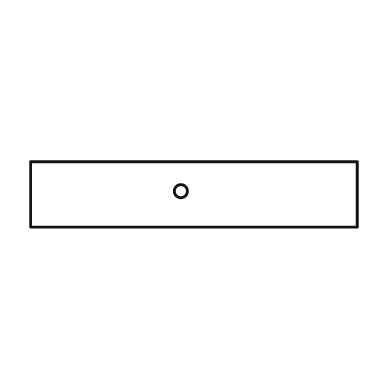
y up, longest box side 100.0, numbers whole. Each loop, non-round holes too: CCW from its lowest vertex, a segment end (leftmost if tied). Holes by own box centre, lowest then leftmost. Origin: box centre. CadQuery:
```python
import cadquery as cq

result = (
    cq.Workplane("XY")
    .moveTo(-50.0, -10.0)
    .lineTo(50.0, -10.0)
    .lineTo(50.0, 10.0)
    .lineTo(-50.0, 10.0)
    .close()
    .moveTo(-4.0, 1.0)
    .circle(2.0)
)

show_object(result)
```